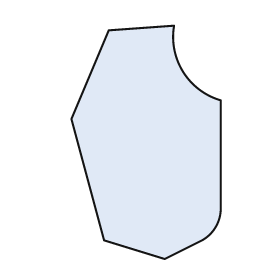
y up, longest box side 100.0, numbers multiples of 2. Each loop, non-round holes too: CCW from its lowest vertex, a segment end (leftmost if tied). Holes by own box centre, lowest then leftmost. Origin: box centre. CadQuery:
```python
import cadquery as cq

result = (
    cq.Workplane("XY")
    .moveTo(8.0, -50.0)
    .lineTo(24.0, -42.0)
    .threePointArc((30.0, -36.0), (32.0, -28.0))
    .lineTo(32.0, 18.0)
    .threePointArc((16.0, 30.0), (12.0, 50.0))
    .lineTo(-16.0, 48.0)
    .lineTo(-32.0, 10.0)
    .lineTo(-18.0, -42.0)
    .close()
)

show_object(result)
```